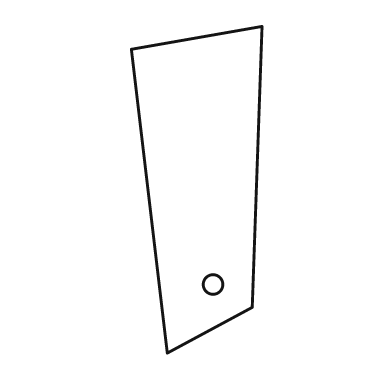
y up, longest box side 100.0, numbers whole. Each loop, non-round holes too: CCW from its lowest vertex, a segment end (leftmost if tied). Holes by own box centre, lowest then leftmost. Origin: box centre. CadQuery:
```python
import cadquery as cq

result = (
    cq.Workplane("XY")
    .moveTo(-9.0, -50.0)
    .lineTo(17.0, -36.0)
    .lineTo(20.0, 50.0)
    .lineTo(-20.0, 43.0)
    .close()
    .moveTo(5.0, -29.0)
    .circle(3.0)
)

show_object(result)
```